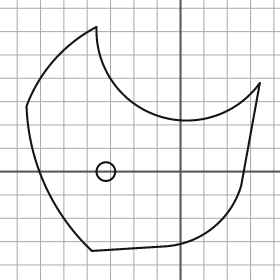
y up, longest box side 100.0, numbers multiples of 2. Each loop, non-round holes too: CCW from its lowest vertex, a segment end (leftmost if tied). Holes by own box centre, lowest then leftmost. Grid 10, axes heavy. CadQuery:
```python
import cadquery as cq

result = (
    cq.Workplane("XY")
    .moveTo(-38.0, -34.0)
    .lineTo(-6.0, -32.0)
    .threePointArc((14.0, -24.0), (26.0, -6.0))
    .lineTo(34.0, 38.0)
    .threePointArc((-10.0, 24.0), (-36.0, 62.0))
    .threePointArc((-54.0, 48.0), (-66.0, 28.0))
    .threePointArc((-58.0, -6.0), (-38.0, -34.0))
    .close()
    .moveTo(-32.0, 0.0)
    .circle(4.0)
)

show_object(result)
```